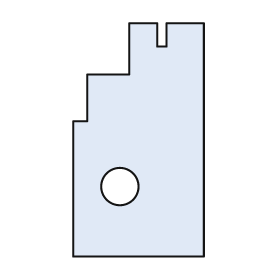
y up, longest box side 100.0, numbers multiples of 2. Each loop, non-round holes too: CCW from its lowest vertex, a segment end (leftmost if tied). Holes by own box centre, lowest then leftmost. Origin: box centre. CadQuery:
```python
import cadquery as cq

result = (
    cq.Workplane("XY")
    .moveTo(-28.0, -50.0)
    .lineTo(28.0, -50.0)
    .lineTo(28.0, 50.0)
    .lineTo(12.0, 50.0)
    .lineTo(12.0, 40.0)
    .lineTo(8.0, 40.0)
    .lineTo(8.0, 50.0)
    .lineTo(-4.0, 50.0)
    .lineTo(-4.0, 28.0)
    .lineTo(-22.0, 28.0)
    .lineTo(-22.0, 8.0)
    .lineTo(-28.0, 8.0)
    .close()
    .moveTo(-8.0, -20.0)
    .circle(8.0)
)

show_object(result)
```